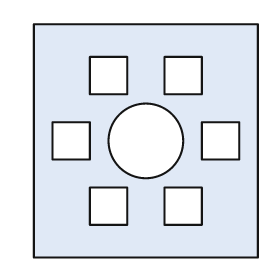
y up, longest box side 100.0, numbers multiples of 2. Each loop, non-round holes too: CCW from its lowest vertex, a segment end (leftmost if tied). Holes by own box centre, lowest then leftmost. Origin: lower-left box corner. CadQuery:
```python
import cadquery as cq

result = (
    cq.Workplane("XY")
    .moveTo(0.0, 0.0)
    .lineTo(96.0, 0.0)
    .lineTo(96.0, 100.0)
    .lineTo(0.0, 100.0)
    .close()
    .moveTo(24.0, 14.0)
    .lineTo(40.0, 14.0)
    .lineTo(40.0, 30.0)
    .lineTo(24.0, 30.0)
    .close()
    .moveTo(56.0, 14.0)
    .lineTo(72.0, 14.0)
    .lineTo(72.0, 30.0)
    .lineTo(56.0, 30.0)
    .close()
    .moveTo(8.0, 42.0)
    .lineTo(24.0, 42.0)
    .lineTo(24.0, 58.0)
    .lineTo(8.0, 58.0)
    .close()
    .moveTo(48.0, 50.0)
    .circle(16.0)
    .moveTo(72.0, 42.0)
    .lineTo(88.0, 42.0)
    .lineTo(88.0, 58.0)
    .lineTo(72.0, 58.0)
    .close()
    .moveTo(24.0, 70.0)
    .lineTo(40.0, 70.0)
    .lineTo(40.0, 86.0)
    .lineTo(24.0, 86.0)
    .close()
    .moveTo(56.0, 70.0)
    .lineTo(72.0, 70.0)
    .lineTo(72.0, 86.0)
    .lineTo(56.0, 86.0)
    .close()
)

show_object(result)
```